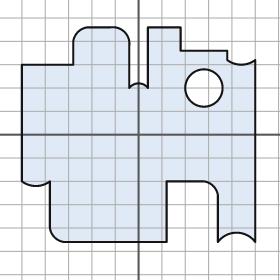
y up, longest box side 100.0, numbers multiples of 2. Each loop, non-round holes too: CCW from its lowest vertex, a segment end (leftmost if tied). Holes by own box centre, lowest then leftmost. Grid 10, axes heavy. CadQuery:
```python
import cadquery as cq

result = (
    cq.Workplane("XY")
    .moveTo(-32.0, -46.0)
    .lineTo(12.0, -46.0)
    .lineTo(12.0, -20.0)
    .lineTo(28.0, -20.0)
    .threePointArc((32.0, -22.0), (34.0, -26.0))
    .lineTo(34.0, -46.0)
    .threePointArc((42.0, -42.0), (50.0, -46.0))
    .lineTo(50.0, 32.0)
    .threePointArc((44.0, 30.0), (38.0, 32.0))
    .lineTo(38.0, 36.0)
    .lineTo(18.0, 36.0)
    .lineTo(18.0, 46.0)
    .lineTo(4.0, 46.0)
    .lineTo(4.0, 20.0)
    .threePointArc((0.0, 22.0), (-4.0, 20.0))
    .lineTo(-4.0, 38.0)
    .threePointArc((-6.0, 44.0), (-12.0, 46.0))
    .lineTo(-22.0, 46.0)
    .threePointArc((-26.0, 44.0), (-28.0, 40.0))
    .lineTo(-28.0, 30.0)
    .lineTo(-50.0, 30.0)
    .lineTo(-50.0, -20.0)
    .threePointArc((-44.0, -22.0), (-38.0, -20.0))
    .lineTo(-38.0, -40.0)
    .threePointArc((-36.0, -44.0), (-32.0, -46.0))
    .close()
    .moveTo(28.0, 20.0)
    .circle(8.0)
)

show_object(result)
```